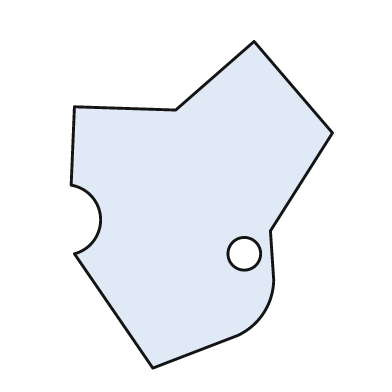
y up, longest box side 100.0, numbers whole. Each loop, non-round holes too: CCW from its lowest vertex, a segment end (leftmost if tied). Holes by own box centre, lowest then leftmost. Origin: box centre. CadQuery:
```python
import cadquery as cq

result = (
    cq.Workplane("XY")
    .moveTo(-15.0, -50.0)
    .lineTo(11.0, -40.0)
    .threePointArc((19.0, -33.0), (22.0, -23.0))
    .lineTo(21.0, -8.0)
    .lineTo(40.0, 22.0)
    .lineTo(16.0, 50.0)
    .lineTo(-8.0, 29.0)
    .lineTo(-39.0, 30.0)
    .lineTo(-40.0, 6.0)
    .threePointArc((-31.0, -4.0), (-39.0, -15.0))
    .close()
    .moveTo(13.0, -15.0)
    .circle(5.0)
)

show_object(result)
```